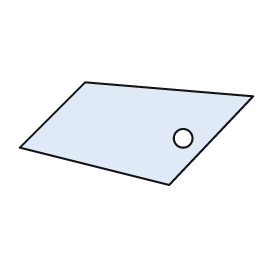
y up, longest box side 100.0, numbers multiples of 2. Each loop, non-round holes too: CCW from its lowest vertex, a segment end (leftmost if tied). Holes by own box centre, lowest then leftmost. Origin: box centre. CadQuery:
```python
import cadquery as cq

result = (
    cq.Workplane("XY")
    .moveTo(14.0, -22.0)
    .lineTo(50.0, 16.0)
    .lineTo(-22.0, 22.0)
    .lineTo(-50.0, -6.0)
    .close()
    .moveTo(20.0, -2.0)
    .circle(4.0)
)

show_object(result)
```